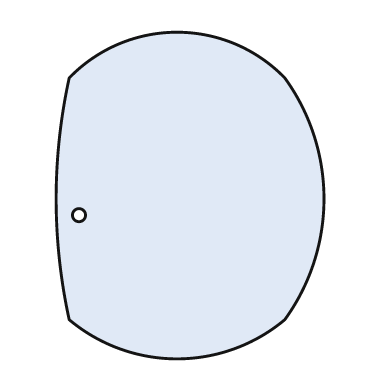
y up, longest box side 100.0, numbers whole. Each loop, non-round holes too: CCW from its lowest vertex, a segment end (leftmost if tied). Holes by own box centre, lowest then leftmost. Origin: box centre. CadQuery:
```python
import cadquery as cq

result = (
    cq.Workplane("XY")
    .moveTo(-37.0, -38.0)
    .threePointArc((-4.0, -50.0), (29.0, -38.0))
    .threePointArc((41.0, -1.0), (29.0, 36.0))
    .threePointArc((-4.0, 50.0), (-37.0, 36.0))
    .threePointArc((-41.0, -1.0), (-37.0, -38.0))
    .close()
    .moveTo(-34.0, -6.0)
    .circle(2.0)
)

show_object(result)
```